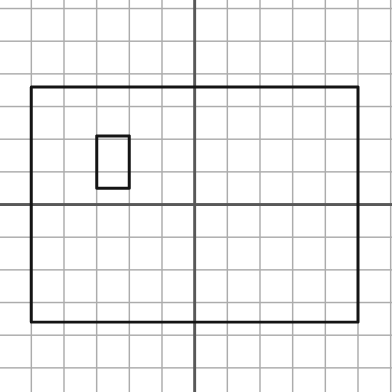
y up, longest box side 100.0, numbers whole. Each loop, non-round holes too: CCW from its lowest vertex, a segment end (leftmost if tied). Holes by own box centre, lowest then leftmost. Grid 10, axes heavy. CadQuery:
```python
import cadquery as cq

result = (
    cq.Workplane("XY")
    .moveTo(-50.0, -36.0)
    .lineTo(50.0, -36.0)
    .lineTo(50.0, 36.0)
    .lineTo(-50.0, 36.0)
    .close()
    .moveTo(-30.0, 5.0)
    .lineTo(-20.0, 5.0)
    .lineTo(-20.0, 21.0)
    .lineTo(-30.0, 21.0)
    .close()
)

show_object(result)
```